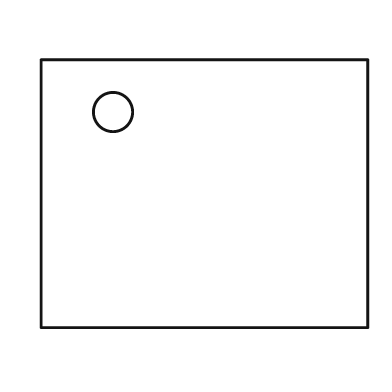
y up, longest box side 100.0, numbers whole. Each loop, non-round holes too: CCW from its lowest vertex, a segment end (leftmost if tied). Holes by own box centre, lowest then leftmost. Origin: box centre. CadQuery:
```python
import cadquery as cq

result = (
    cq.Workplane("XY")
    .moveTo(-50.0, -41.0)
    .lineTo(50.0, -41.0)
    .lineTo(50.0, 41.0)
    .lineTo(-50.0, 41.0)
    .close()
    .moveTo(-28.0, 25.0)
    .circle(6.0)
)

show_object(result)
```